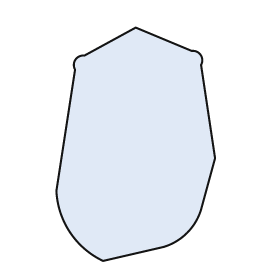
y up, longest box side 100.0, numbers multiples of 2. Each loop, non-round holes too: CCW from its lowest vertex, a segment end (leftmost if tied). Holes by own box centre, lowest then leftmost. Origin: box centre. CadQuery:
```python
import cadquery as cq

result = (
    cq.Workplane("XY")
    .moveTo(-14.0, -50.0)
    .lineTo(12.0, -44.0)
    .threePointArc((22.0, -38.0), (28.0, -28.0))
    .lineTo(34.0, -6.0)
    .lineTo(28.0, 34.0)
    .threePointArc((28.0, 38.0), (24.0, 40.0))
    .lineTo(0.0, 50.0)
    .lineTo(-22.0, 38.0)
    .threePointArc((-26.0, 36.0), (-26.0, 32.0))
    .lineTo(-34.0, -20.0)
    .threePointArc((-28.0, -38.0), (-14.0, -50.0))
    .close()
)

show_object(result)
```